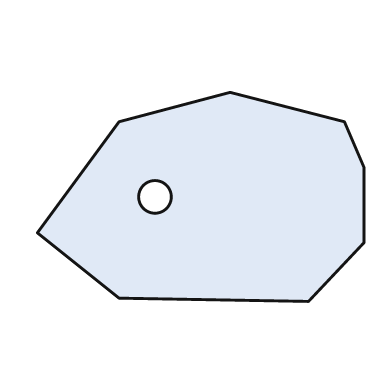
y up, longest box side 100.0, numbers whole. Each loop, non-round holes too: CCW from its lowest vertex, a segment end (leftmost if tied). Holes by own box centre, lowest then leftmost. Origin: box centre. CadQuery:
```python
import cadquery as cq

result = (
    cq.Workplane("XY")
    .moveTo(33.0, -32.0)
    .lineTo(50.0, -14.0)
    .lineTo(50.0, 9.0)
    .lineTo(44.0, 23.0)
    .lineTo(9.0, 32.0)
    .lineTo(-25.0, 23.0)
    .lineTo(-50.0, -11.0)
    .lineTo(-25.0, -31.0)
    .close()
    .moveTo(-14.0, 0.0)
    .circle(5.0)
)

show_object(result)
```